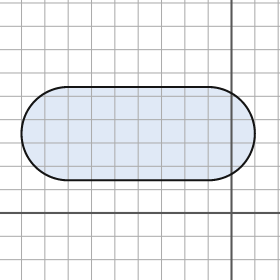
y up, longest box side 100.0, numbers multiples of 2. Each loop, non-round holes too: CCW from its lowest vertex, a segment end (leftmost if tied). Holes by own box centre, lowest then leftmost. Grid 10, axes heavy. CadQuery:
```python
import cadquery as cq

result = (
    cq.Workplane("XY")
    .moveTo(-70.0, 14.0)
    .lineTo(-10.0, 14.0)
    .threePointArc((10.0, 34.0), (-10.0, 54.0))
    .lineTo(-70.0, 54.0)
    .threePointArc((-90.0, 34.0), (-70.0, 14.0))
    .close()
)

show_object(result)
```